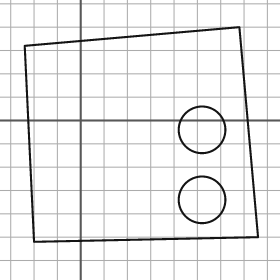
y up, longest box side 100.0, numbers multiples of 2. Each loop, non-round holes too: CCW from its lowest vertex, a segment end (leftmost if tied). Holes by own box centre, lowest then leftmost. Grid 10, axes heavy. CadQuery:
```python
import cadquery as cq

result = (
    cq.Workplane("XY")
    .moveTo(-20.0, -52.0)
    .lineTo(76.0, -50.0)
    .lineTo(68.0, 40.0)
    .lineTo(-24.0, 32.0)
    .close()
    .moveTo(52.0, -34.0)
    .circle(10.0)
    .moveTo(52.0, -4.0)
    .circle(10.0)
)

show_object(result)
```